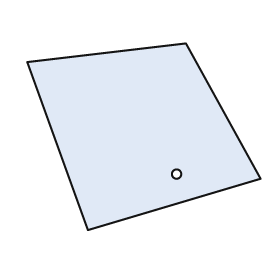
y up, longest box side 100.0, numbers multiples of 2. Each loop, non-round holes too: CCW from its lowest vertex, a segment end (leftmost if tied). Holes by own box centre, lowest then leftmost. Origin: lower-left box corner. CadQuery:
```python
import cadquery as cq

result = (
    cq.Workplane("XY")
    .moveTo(26.0, 0.0)
    .lineTo(100.0, 22.0)
    .lineTo(68.0, 80.0)
    .lineTo(0.0, 72.0)
    .close()
    .moveTo(64.0, 24.0)
    .circle(2.0)
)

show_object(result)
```